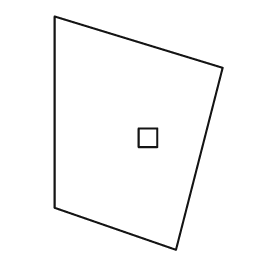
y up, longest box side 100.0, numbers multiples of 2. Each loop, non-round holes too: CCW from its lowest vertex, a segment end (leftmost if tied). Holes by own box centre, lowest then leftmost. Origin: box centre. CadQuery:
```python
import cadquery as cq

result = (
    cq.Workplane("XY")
    .moveTo(16.0, -50.0)
    .lineTo(36.0, 28.0)
    .lineTo(-36.0, 50.0)
    .lineTo(-36.0, -32.0)
    .close()
    .moveTo(0.0, -6.0)
    .lineTo(8.0, -6.0)
    .lineTo(8.0, 2.0)
    .lineTo(0.0, 2.0)
    .close()
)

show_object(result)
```